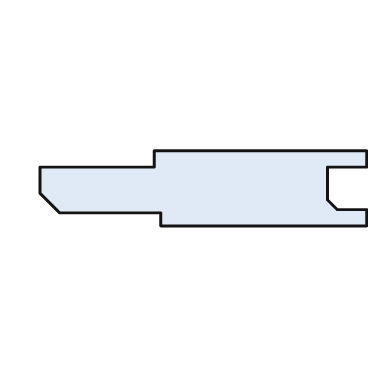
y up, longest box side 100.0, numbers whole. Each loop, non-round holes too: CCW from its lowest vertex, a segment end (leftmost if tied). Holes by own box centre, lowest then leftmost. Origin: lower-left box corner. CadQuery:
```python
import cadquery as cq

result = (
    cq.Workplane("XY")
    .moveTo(37.0, 0.0)
    .lineTo(100.0, 0.0)
    .lineTo(100.0, 5.0)
    .lineTo(91.0, 5.0)
    .lineTo(88.0, 8.0)
    .lineTo(88.0, 18.0)
    .lineTo(100.0, 18.0)
    .lineTo(100.0, 23.0)
    .lineTo(35.0, 23.0)
    .lineTo(35.0, 18.0)
    .lineTo(0.0, 18.0)
    .lineTo(0.0, 10.0)
    .lineTo(6.0, 4.0)
    .lineTo(37.0, 4.0)
    .close()
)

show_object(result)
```